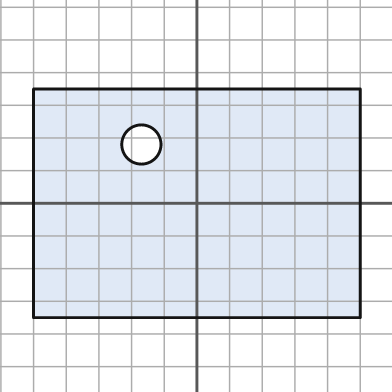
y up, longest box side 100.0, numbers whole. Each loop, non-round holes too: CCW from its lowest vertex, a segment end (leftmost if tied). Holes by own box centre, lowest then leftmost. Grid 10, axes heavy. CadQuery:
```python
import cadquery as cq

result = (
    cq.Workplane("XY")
    .moveTo(-50.0, -35.0)
    .lineTo(50.0, -35.0)
    .lineTo(50.0, 35.0)
    .lineTo(-50.0, 35.0)
    .close()
    .moveTo(-17.0, 18.0)
    .circle(6.0)
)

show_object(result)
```